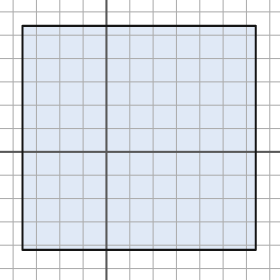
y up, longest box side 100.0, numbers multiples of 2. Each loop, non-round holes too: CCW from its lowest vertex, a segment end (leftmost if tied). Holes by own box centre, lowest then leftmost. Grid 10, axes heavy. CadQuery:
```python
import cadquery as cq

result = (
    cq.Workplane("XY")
    .moveTo(-36.0, -42.0)
    .lineTo(64.0, -42.0)
    .lineTo(64.0, 54.0)
    .lineTo(-36.0, 54.0)
    .close()
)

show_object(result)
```